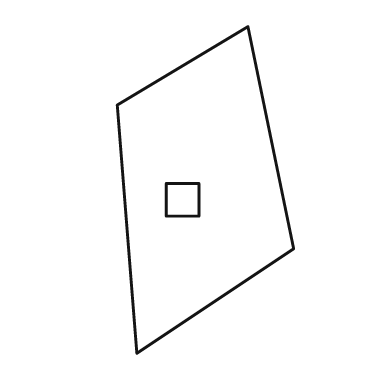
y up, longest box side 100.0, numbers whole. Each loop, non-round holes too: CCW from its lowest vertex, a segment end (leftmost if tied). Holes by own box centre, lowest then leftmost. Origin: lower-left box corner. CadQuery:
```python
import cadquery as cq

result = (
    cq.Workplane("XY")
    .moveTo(6.0, 0.0)
    .lineTo(54.0, 32.0)
    .lineTo(40.0, 100.0)
    .lineTo(0.0, 76.0)
    .close()
    .moveTo(15.0, 42.0)
    .lineTo(25.0, 42.0)
    .lineTo(25.0, 52.0)
    .lineTo(15.0, 52.0)
    .close()
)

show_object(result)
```